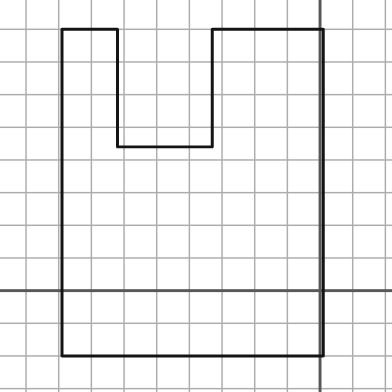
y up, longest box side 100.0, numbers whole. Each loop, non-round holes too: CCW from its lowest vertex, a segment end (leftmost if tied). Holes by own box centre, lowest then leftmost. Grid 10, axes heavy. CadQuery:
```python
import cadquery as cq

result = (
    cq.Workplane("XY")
    .moveTo(-79.0, -20.0)
    .lineTo(1.0, -20.0)
    .lineTo(1.0, 80.0)
    .lineTo(-33.0, 80.0)
    .lineTo(-33.0, 44.0)
    .lineTo(-62.0, 44.0)
    .lineTo(-62.0, 80.0)
    .lineTo(-79.0, 80.0)
    .close()
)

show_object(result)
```